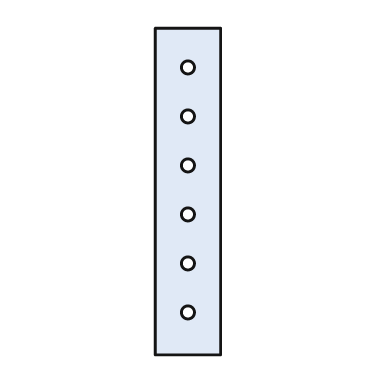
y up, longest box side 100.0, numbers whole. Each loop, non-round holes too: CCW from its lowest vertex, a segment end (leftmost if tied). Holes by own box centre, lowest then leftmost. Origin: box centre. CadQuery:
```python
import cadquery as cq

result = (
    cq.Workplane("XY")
    .moveTo(-10.0, -50.0)
    .lineTo(10.0, -50.0)
    .lineTo(10.0, 50.0)
    .lineTo(-10.0, 50.0)
    .close()
    .moveTo(0.0, -37.0)
    .circle(2.0)
    .moveTo(0.0, -22.0)
    .circle(2.0)
    .moveTo(0.0, -7.0)
    .circle(2.0)
    .moveTo(0.0, 8.0)
    .circle(2.0)
    .moveTo(0.0, 23.0)
    .circle(2.0)
    .moveTo(0.0, 38.0)
    .circle(2.0)
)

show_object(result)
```